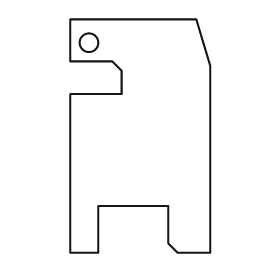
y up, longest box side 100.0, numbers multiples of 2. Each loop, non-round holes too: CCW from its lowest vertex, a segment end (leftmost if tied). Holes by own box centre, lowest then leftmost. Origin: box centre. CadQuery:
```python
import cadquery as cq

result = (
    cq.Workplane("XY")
    .moveTo(-30.0, -50.0)
    .lineTo(-18.0, -50.0)
    .lineTo(-18.0, -30.0)
    .lineTo(12.0, -30.0)
    .lineTo(12.0, -46.0)
    .lineTo(16.0, -50.0)
    .lineTo(30.0, -50.0)
    .lineTo(30.0, 30.0)
    .lineTo(24.0, 50.0)
    .lineTo(-30.0, 50.0)
    .lineTo(-30.0, 32.0)
    .lineTo(-12.0, 32.0)
    .lineTo(-8.0, 28.0)
    .lineTo(-8.0, 18.0)
    .lineTo(-30.0, 18.0)
    .close()
    .moveTo(-22.0, 40.0)
    .circle(4.0)
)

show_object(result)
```